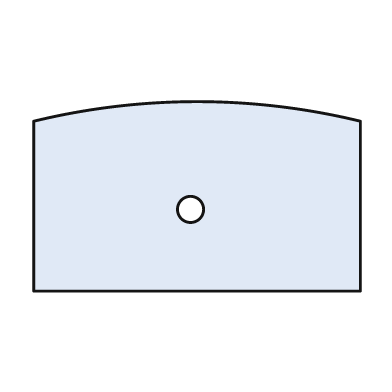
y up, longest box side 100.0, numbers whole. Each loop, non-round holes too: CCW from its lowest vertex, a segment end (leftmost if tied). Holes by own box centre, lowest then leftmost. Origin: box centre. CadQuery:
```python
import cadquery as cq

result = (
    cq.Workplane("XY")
    .moveTo(-50.0, -29.0)
    .lineTo(50.0, -29.0)
    .lineTo(50.0, 23.0)
    .threePointArc((0.0, 29.0), (-50.0, 23.0))
    .close()
    .moveTo(-2.0, -4.0)
    .circle(4.0)
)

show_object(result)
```